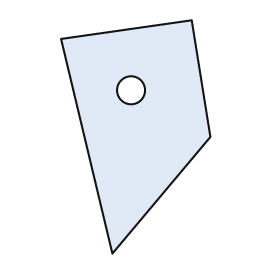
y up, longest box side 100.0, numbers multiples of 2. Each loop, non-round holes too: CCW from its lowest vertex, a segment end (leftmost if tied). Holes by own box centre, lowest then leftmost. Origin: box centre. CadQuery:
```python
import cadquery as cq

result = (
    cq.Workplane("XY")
    .moveTo(-10.0, -50.0)
    .lineTo(32.0, 0.0)
    .lineTo(24.0, 50.0)
    .lineTo(-32.0, 42.0)
    .close()
    .moveTo(-2.0, 20.0)
    .circle(6.0)
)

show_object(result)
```